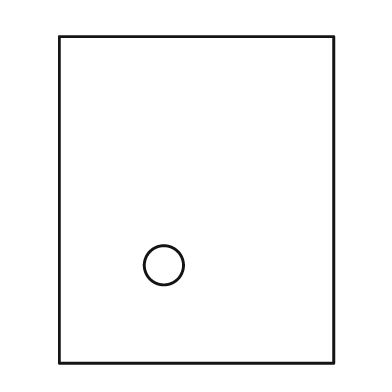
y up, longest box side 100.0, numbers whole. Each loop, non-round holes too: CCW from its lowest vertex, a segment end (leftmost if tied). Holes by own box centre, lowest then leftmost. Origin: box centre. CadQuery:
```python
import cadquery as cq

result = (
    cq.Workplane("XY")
    .moveTo(-42.0, -50.0)
    .lineTo(42.0, -50.0)
    .lineTo(42.0, 50.0)
    .lineTo(-42.0, 50.0)
    .close()
    .moveTo(-10.0, -20.0)
    .circle(6.0)
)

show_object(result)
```